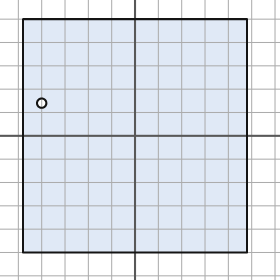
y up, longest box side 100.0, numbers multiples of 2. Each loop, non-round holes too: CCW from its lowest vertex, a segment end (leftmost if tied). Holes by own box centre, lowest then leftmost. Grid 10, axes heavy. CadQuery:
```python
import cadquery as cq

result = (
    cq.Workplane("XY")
    .moveTo(-48.0, -50.0)
    .lineTo(48.0, -50.0)
    .lineTo(48.0, 50.0)
    .lineTo(-48.0, 50.0)
    .close()
    .moveTo(-40.0, 14.0)
    .circle(2.0)
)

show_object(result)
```